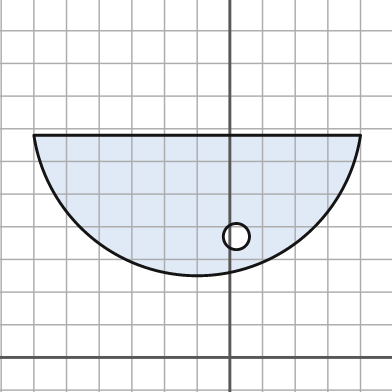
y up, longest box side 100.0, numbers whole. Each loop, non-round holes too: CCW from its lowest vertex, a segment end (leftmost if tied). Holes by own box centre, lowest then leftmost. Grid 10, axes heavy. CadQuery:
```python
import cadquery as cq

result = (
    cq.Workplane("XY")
    .moveTo(-60.0, 68.0)
    .threePointArc((-10.0, 25.0), (40.0, 68.0))
    .close()
    .moveTo(2.0, 37.0)
    .circle(4.0)
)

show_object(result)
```